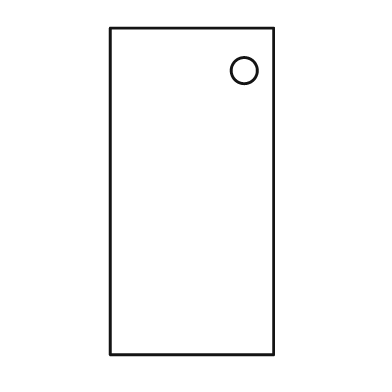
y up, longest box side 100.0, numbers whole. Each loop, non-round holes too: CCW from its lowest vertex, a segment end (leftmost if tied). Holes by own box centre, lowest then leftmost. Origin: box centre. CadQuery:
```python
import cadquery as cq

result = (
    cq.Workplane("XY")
    .moveTo(-25.0, -50.0)
    .lineTo(25.0, -50.0)
    .lineTo(25.0, 50.0)
    .lineTo(-25.0, 50.0)
    .close()
    .moveTo(16.0, 37.0)
    .circle(4.0)
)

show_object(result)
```